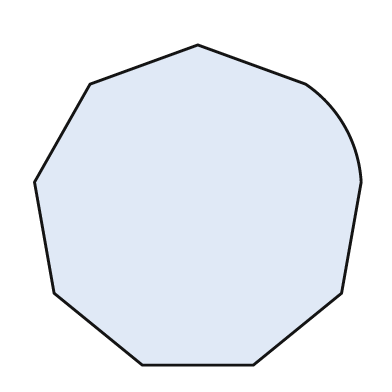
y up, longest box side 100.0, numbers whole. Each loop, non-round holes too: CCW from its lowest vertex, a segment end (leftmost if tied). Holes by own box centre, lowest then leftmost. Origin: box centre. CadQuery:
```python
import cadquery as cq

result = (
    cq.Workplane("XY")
    .moveTo(-17.0, -49.0)
    .lineTo(17.0, -49.0)
    .lineTo(44.0, -27.0)
    .lineTo(50.0, 7.0)
    .threePointArc((45.0, 24.0), (33.0, 37.0))
    .lineTo(0.0, 49.0)
    .lineTo(-33.0, 37.0)
    .lineTo(-50.0, 7.0)
    .lineTo(-44.0, -27.0)
    .close()
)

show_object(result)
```